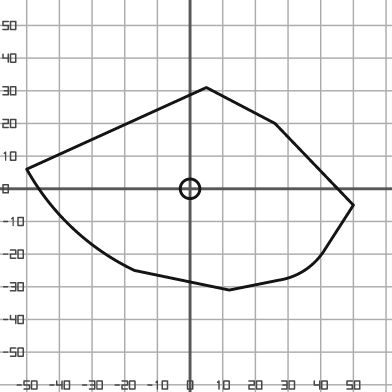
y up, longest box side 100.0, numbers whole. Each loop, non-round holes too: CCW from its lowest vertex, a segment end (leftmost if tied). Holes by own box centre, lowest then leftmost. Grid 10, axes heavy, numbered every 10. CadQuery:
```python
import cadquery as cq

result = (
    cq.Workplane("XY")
    .moveTo(12.0, -31.0)
    .lineTo(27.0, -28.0)
    .threePointArc((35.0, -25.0), (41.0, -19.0))
    .lineTo(50.0, -5.0)
    .lineTo(26.0, 20.0)
    .lineTo(5.0, 31.0)
    .lineTo(-50.0, 6.0)
    .threePointArc((-36.0, -12.0), (-17.0, -25.0))
    .close()
    .moveTo(0.0, 0.0)
    .circle(3.0)
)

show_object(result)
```